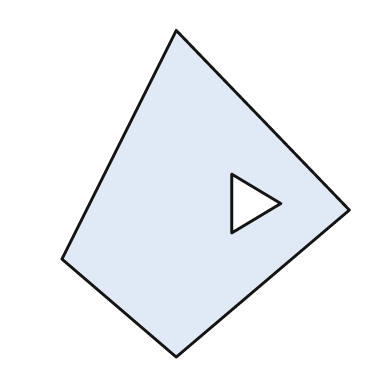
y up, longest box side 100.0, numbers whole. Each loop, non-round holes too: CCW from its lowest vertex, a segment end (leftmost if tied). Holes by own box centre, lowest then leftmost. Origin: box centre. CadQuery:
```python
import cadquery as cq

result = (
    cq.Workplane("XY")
    .moveTo(-9.0, -50.0)
    .lineTo(44.0, -5.0)
    .lineTo(-9.0, 50.0)
    .lineTo(-44.0, -20.0)
    .close()
    .moveTo(8.0, -12.0)
    .lineTo(23.0, -3.0)
    .lineTo(8.0, 6.0)
    .close()
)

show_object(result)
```